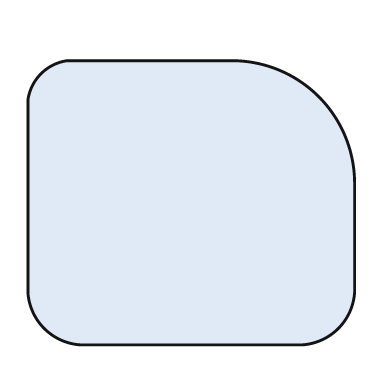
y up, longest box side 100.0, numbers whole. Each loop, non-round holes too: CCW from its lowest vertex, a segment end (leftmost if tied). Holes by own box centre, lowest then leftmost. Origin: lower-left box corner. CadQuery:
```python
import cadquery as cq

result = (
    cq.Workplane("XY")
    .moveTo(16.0, 0.0)
    .lineTo(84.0, 0.0)
    .threePointArc((95.0, 5.0), (100.0, 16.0))
    .lineTo(100.0, 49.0)
    .threePointArc((89.0, 76.0), (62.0, 87.0))
    .lineTo(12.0, 87.0)
    .threePointArc((4.0, 83.0), (0.0, 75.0))
    .lineTo(0.0, 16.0)
    .threePointArc((5.0, 5.0), (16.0, 0.0))
    .close()
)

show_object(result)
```